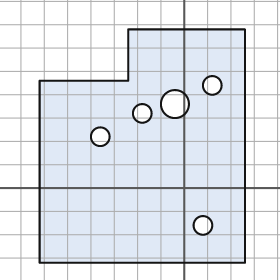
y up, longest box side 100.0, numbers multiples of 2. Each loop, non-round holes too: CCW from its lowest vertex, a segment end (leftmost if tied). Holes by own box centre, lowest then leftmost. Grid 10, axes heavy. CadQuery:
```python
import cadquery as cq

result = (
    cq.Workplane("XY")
    .moveTo(-62.0, -32.0)
    .lineTo(26.0, -32.0)
    .lineTo(26.0, 68.0)
    .lineTo(-24.0, 68.0)
    .lineTo(-24.0, 46.0)
    .lineTo(-62.0, 46.0)
    .close()
    .moveTo(8.0, -16.0)
    .circle(4.0)
    .moveTo(-36.0, 22.0)
    .circle(4.0)
    .moveTo(-18.0, 32.0)
    .circle(4.0)
    .moveTo(-4.0, 36.0)
    .circle(6.0)
    .moveTo(12.0, 44.0)
    .circle(4.0)
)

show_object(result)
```